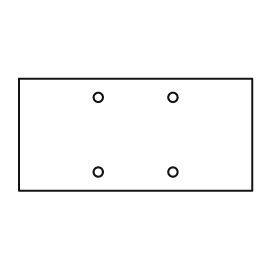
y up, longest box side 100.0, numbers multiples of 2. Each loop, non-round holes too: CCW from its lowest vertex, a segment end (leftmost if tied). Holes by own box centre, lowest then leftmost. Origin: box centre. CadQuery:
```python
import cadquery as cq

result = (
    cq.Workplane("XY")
    .moveTo(-50.0, -24.0)
    .lineTo(50.0, -24.0)
    .lineTo(50.0, 24.0)
    .lineTo(-50.0, 24.0)
    .close()
    .moveTo(-16.0, -16.0)
    .circle(2.0)
    .moveTo(16.0, -16.0)
    .circle(2.0)
    .moveTo(-16.0, 16.0)
    .circle(2.0)
    .moveTo(16.0, 16.0)
    .circle(2.0)
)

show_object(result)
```